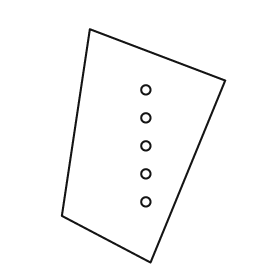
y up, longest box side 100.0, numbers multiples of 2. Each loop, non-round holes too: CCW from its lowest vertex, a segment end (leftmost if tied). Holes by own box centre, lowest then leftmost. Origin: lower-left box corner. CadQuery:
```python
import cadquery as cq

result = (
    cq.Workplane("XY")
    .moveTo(38.0, 0.0)
    .lineTo(70.0, 78.0)
    .lineTo(12.0, 100.0)
    .lineTo(0.0, 20.0)
    .close()
    .moveTo(36.0, 26.0)
    .circle(2.0)
    .moveTo(36.0, 38.0)
    .circle(2.0)
    .moveTo(36.0, 50.0)
    .circle(2.0)
    .moveTo(36.0, 62.0)
    .circle(2.0)
    .moveTo(36.0, 74.0)
    .circle(2.0)
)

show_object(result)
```